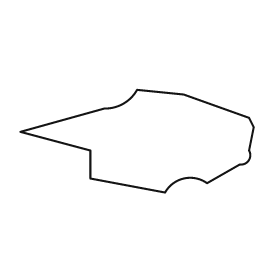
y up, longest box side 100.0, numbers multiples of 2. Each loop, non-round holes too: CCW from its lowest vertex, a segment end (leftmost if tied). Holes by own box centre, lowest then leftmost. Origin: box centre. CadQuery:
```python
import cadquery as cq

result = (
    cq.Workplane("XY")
    .moveTo(12.0, -22.0)
    .threePointArc((20.0, -16.0), (30.0, -18.0))
    .lineTo(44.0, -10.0)
    .threePointArc((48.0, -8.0), (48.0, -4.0))
    .lineTo(50.0, 6.0)
    .lineTo(48.0, 10.0)
    .lineTo(20.0, 20.0)
    .lineTo(0.0, 22.0)
    .threePointArc((-6.0, 16.0), (-14.0, 14.0))
    .lineTo(-50.0, 4.0)
    .lineTo(-20.0, -4.0)
    .lineTo(-20.0, -16.0)
    .close()
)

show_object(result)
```